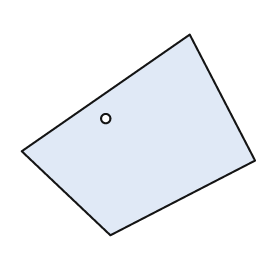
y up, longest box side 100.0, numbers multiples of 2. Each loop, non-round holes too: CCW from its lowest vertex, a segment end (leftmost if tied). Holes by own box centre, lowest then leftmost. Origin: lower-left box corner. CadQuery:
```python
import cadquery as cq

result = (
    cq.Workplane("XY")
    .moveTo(38.0, 0.0)
    .lineTo(100.0, 32.0)
    .lineTo(72.0, 86.0)
    .lineTo(0.0, 36.0)
    .close()
    .moveTo(36.0, 50.0)
    .circle(2.0)
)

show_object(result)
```